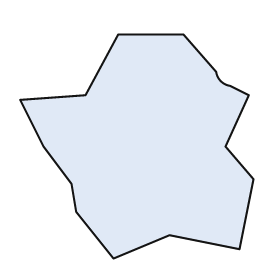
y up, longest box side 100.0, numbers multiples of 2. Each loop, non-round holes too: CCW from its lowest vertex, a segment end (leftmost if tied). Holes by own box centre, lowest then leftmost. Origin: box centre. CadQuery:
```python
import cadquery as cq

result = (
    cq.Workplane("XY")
    .moveTo(-10.0, -48.0)
    .lineTo(14.0, -38.0)
    .lineTo(44.0, -44.0)
    .lineTo(50.0, -14.0)
    .lineTo(38.0, 0.0)
    .lineTo(48.0, 22.0)
    .lineTo(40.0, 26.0)
    .threePointArc((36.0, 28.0), (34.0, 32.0))
    .lineTo(20.0, 48.0)
    .lineTo(-8.0, 48.0)
    .lineTo(-22.0, 22.0)
    .lineTo(-50.0, 20.0)
    .lineTo(-40.0, 0.0)
    .lineTo(-28.0, -16.0)
    .lineTo(-26.0, -28.0)
    .close()
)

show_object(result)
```